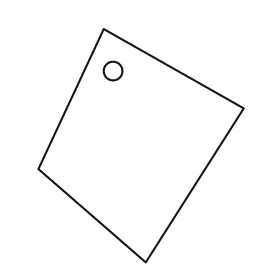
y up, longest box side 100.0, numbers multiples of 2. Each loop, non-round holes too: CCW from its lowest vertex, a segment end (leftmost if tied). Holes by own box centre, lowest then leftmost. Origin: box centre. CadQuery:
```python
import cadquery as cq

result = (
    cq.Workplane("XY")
    .moveTo(2.0, -50.0)
    .lineTo(44.0, 16.0)
    .lineTo(-16.0, 50.0)
    .lineTo(-44.0, -10.0)
    .close()
    .moveTo(-12.0, 32.0)
    .circle(4.0)
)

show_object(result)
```